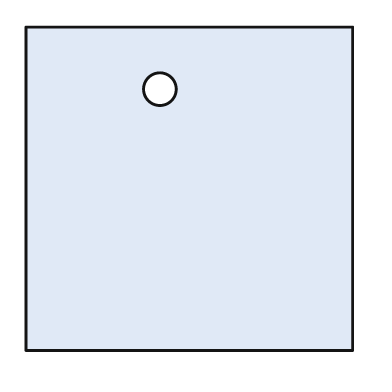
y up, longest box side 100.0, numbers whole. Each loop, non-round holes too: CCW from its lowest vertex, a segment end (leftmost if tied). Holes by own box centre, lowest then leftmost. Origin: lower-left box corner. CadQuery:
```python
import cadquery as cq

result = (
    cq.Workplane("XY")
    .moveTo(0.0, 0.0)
    .lineTo(100.0, 0.0)
    .lineTo(100.0, 99.0)
    .lineTo(0.0, 99.0)
    .close()
    .moveTo(41.0, 80.0)
    .circle(5.0)
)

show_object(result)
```